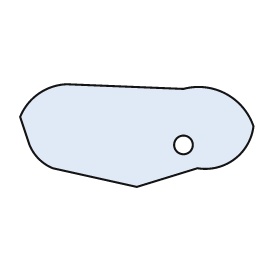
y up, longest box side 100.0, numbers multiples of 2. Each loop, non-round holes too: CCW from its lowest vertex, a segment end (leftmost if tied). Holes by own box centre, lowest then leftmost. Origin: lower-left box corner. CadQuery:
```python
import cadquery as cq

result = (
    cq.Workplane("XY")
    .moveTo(50.0, 0.0)
    .lineTo(76.0, 8.0)
    .threePointArc((92.0, 12.0), (100.0, 26.0))
    .threePointArc((88.0, 40.0), (70.0, 42.0))
    .lineTo(20.0, 44.0)
    .threePointArc((8.0, 40.0), (0.0, 30.0))
    .lineTo(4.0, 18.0)
    .threePointArc((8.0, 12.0), (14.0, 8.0))
    .close()
    .moveTo(70.0, 18.0)
    .circle(4.0)
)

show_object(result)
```